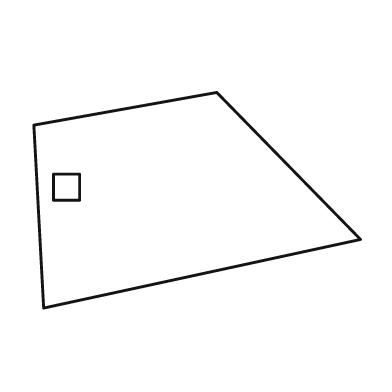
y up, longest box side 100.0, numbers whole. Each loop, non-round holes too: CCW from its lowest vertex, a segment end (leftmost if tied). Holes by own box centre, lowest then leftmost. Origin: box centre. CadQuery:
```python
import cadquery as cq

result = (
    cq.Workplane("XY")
    .moveTo(-47.0, -33.0)
    .lineTo(50.0, -12.0)
    .lineTo(6.0, 33.0)
    .lineTo(-50.0, 23.0)
    .close()
    .moveTo(-44.0, 0.0)
    .lineTo(-36.0, 0.0)
    .lineTo(-36.0, 8.0)
    .lineTo(-44.0, 8.0)
    .close()
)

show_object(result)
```